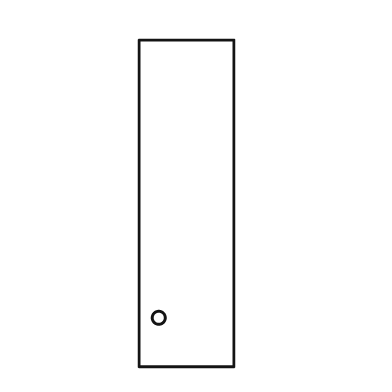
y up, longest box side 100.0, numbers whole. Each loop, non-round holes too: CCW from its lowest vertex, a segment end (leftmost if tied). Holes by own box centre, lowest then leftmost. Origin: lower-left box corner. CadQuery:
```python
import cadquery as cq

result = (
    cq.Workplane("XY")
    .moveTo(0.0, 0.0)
    .lineTo(29.0, 0.0)
    .lineTo(29.0, 100.0)
    .lineTo(0.0, 100.0)
    .close()
    .moveTo(6.0, 15.0)
    .circle(2.0)
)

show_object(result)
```